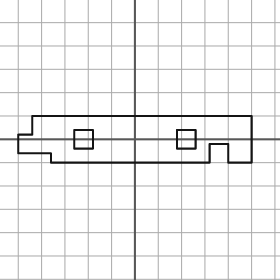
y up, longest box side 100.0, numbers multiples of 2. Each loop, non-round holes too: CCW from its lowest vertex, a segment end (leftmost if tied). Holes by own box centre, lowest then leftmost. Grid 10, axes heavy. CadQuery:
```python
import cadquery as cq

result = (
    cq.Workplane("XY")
    .moveTo(-36.0, -10.0)
    .lineTo(32.0, -10.0)
    .lineTo(32.0, -2.0)
    .lineTo(40.0, -2.0)
    .lineTo(40.0, -10.0)
    .lineTo(50.0, -10.0)
    .lineTo(50.0, 10.0)
    .lineTo(-44.0, 10.0)
    .lineTo(-44.0, 2.0)
    .lineTo(-50.0, 2.0)
    .lineTo(-50.0, -6.0)
    .lineTo(-36.0, -6.0)
    .close()
    .moveTo(-26.0, -4.0)
    .lineTo(-18.0, -4.0)
    .lineTo(-18.0, 4.0)
    .lineTo(-26.0, 4.0)
    .close()
    .moveTo(18.0, -4.0)
    .lineTo(26.0, -4.0)
    .lineTo(26.0, 4.0)
    .lineTo(18.0, 4.0)
    .close()
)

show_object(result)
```